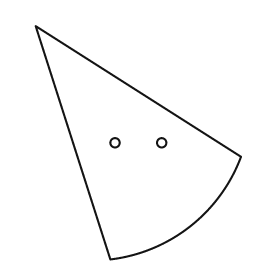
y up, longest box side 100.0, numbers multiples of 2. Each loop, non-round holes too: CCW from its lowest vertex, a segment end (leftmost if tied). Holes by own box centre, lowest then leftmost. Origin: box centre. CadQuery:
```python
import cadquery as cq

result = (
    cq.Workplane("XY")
    .moveTo(-12.0, -50.0)
    .threePointArc((22.0, -36.0), (44.0, -6.0))
    .lineTo(-44.0, 50.0)
    .close()
    .moveTo(-10.0, 0.0)
    .circle(2.0)
    .moveTo(10.0, 0.0)
    .circle(2.0)
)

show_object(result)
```